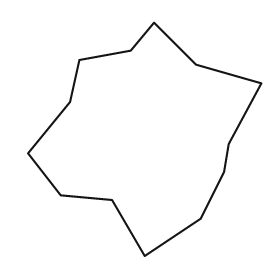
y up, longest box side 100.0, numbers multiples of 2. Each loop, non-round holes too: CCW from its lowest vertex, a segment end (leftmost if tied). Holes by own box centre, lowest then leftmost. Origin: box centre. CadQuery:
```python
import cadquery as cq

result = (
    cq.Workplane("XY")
    .moveTo(0.0, -50.0)
    .lineTo(24.0, -34.0)
    .lineTo(34.0, -14.0)
    .lineTo(36.0, -2.0)
    .lineTo(50.0, 24.0)
    .lineTo(22.0, 32.0)
    .lineTo(4.0, 50.0)
    .lineTo(-6.0, 38.0)
    .lineTo(-28.0, 34.0)
    .lineTo(-32.0, 16.0)
    .lineTo(-50.0, -6.0)
    .lineTo(-36.0, -24.0)
    .lineTo(-14.0, -26.0)
    .close()
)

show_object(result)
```